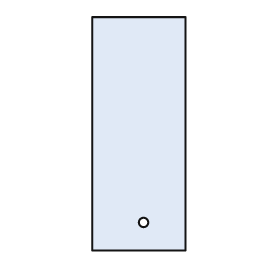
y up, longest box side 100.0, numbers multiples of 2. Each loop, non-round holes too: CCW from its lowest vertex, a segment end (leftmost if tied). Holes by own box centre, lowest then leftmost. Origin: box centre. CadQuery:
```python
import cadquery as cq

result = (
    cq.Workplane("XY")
    .moveTo(-20.0, -50.0)
    .lineTo(20.0, -50.0)
    .lineTo(20.0, 50.0)
    .lineTo(-20.0, 50.0)
    .close()
    .moveTo(2.0, -38.0)
    .circle(2.0)
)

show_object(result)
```